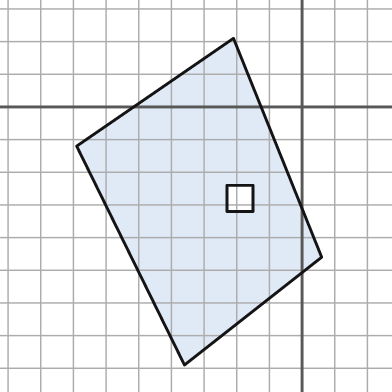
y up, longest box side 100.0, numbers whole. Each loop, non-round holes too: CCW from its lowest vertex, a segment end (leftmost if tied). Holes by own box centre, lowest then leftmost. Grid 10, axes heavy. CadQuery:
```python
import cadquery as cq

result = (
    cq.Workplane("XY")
    .moveTo(-36.0, -79.0)
    .lineTo(6.0, -46.0)
    .lineTo(-21.0, 21.0)
    .lineTo(-69.0, -12.0)
    .close()
    .moveTo(-23.0, -32.0)
    .lineTo(-15.0, -32.0)
    .lineTo(-15.0, -24.0)
    .lineTo(-23.0, -24.0)
    .close()
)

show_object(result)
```